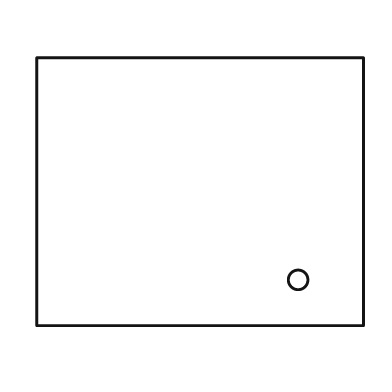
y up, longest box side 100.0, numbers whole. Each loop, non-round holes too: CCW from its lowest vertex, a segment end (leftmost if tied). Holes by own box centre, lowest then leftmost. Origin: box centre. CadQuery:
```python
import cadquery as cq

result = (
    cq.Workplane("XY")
    .moveTo(-50.0, -41.0)
    .lineTo(50.0, -41.0)
    .lineTo(50.0, 41.0)
    .lineTo(-50.0, 41.0)
    .close()
    .moveTo(30.0, -27.0)
    .circle(3.0)
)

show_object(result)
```